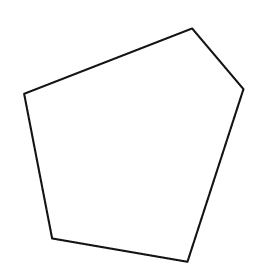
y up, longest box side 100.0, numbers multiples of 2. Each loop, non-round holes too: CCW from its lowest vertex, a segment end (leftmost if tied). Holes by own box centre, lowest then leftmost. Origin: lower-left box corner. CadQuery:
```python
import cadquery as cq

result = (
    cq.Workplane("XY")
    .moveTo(70.0, 0.0)
    .lineTo(94.0, 74.0)
    .lineTo(72.0, 100.0)
    .lineTo(0.0, 72.0)
    .lineTo(12.0, 10.0)
    .close()
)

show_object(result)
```